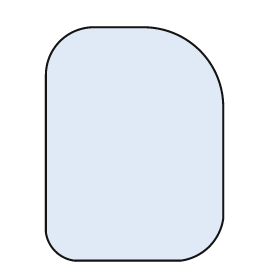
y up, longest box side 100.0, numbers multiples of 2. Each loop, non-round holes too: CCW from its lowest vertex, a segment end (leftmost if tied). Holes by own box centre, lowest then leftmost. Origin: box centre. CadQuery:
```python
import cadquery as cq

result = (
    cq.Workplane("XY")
    .moveTo(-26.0, -50.0)
    .lineTo(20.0, -50.0)
    .threePointArc((32.0, -44.0), (38.0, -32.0))
    .lineTo(38.0, 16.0)
    .threePointArc((28.0, 40.0), (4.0, 50.0))
    .lineTo(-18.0, 50.0)
    .threePointArc((-32.0, 44.0), (-38.0, 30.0))
    .lineTo(-38.0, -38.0)
    .threePointArc((-34.0, -46.0), (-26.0, -50.0))
    .close()
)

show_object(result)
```